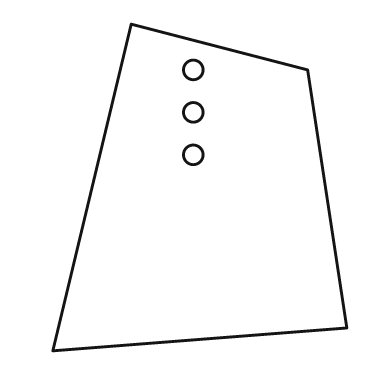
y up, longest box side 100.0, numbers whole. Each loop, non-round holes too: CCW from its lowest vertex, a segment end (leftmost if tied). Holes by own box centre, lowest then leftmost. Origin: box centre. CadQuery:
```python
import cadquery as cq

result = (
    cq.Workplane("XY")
    .moveTo(-45.0, -50.0)
    .lineTo(45.0, -43.0)
    .lineTo(33.0, 36.0)
    .lineTo(-21.0, 50.0)
    .close()
    .moveTo(-2.0, 10.0)
    .circle(3.0)
    .moveTo(-2.0, 23.0)
    .circle(3.0)
    .moveTo(-2.0, 36.0)
    .circle(3.0)
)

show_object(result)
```